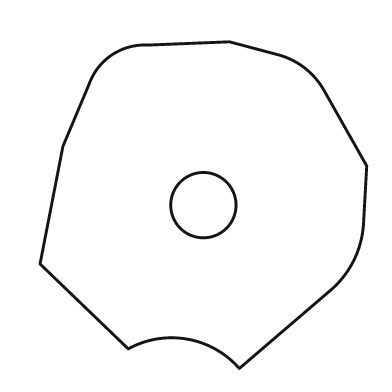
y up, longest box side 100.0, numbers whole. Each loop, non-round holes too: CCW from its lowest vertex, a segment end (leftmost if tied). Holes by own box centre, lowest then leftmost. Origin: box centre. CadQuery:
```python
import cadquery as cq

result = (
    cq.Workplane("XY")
    .moveTo(11.0, -50.0)
    .lineTo(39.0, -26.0)
    .threePointArc((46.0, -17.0), (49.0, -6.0))
    .lineTo(50.0, 12.0)
    .lineTo(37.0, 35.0)
    .threePointArc((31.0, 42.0), (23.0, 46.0))
    .lineTo(8.0, 50.0)
    .lineTo(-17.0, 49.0)
    .threePointArc((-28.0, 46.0), (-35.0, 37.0))
    .lineTo(-43.0, 18.0)
    .lineTo(-50.0, -18.0)
    .lineTo(-23.0, -44.0)
    .threePointArc((-5.0, -41.0), (11.0, -50.0))
    .close()
    .moveTo(0.0, 0.0)
    .circle(10.0)
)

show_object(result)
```